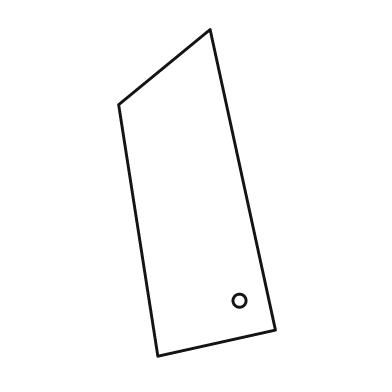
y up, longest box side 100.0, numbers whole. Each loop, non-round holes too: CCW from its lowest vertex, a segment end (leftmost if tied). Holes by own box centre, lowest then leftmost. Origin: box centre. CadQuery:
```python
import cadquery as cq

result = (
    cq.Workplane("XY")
    .moveTo(-12.0, -50.0)
    .lineTo(24.0, -42.0)
    .lineTo(4.0, 50.0)
    .lineTo(-24.0, 27.0)
    .close()
    .moveTo(13.0, -33.0)
    .circle(2.0)
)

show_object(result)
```